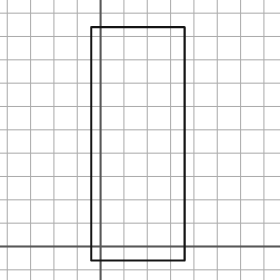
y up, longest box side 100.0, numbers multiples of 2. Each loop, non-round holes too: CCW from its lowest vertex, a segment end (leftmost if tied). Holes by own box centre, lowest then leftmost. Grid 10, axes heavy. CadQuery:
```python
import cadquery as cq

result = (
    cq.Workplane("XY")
    .moveTo(-4.0, -6.0)
    .lineTo(36.0, -6.0)
    .lineTo(36.0, 94.0)
    .lineTo(-4.0, 94.0)
    .close()
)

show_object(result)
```